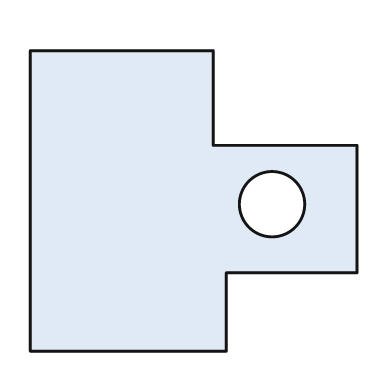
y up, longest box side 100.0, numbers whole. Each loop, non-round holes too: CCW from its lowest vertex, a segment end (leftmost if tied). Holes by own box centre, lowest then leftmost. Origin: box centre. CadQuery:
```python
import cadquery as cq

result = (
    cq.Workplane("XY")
    .moveTo(-50.0, -46.0)
    .lineTo(10.0, -46.0)
    .lineTo(10.0, -22.0)
    .lineTo(50.0, -22.0)
    .lineTo(50.0, 17.0)
    .lineTo(6.0, 17.0)
    .lineTo(6.0, 46.0)
    .lineTo(-50.0, 46.0)
    .close()
    .moveTo(24.0, -1.0)
    .circle(10.0)
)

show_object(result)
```